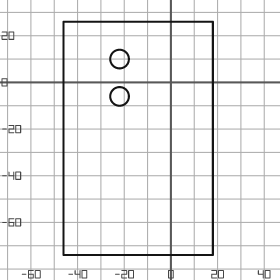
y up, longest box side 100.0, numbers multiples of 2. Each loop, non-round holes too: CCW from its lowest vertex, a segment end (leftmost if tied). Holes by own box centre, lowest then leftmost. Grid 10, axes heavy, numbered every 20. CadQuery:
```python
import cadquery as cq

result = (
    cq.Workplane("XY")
    .moveTo(-46.0, -74.0)
    .lineTo(18.0, -74.0)
    .lineTo(18.0, 26.0)
    .lineTo(-46.0, 26.0)
    .close()
    .moveTo(-22.0, -6.0)
    .circle(4.0)
    .moveTo(-22.0, 10.0)
    .circle(4.0)
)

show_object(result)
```